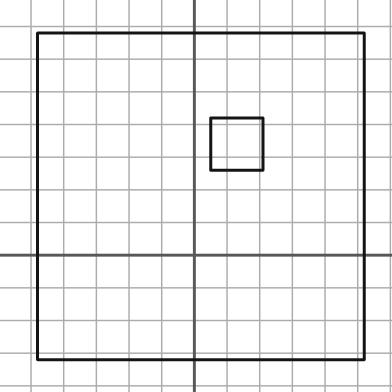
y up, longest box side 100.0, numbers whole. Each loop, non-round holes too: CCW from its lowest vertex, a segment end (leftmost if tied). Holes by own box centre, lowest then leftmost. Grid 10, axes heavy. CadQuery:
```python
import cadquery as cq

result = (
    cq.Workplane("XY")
    .moveTo(-48.0, -32.0)
    .lineTo(52.0, -32.0)
    .lineTo(52.0, 68.0)
    .lineTo(-48.0, 68.0)
    .close()
    .moveTo(5.0, 26.0)
    .lineTo(21.0, 26.0)
    .lineTo(21.0, 42.0)
    .lineTo(5.0, 42.0)
    .close()
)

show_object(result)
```